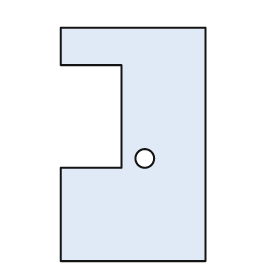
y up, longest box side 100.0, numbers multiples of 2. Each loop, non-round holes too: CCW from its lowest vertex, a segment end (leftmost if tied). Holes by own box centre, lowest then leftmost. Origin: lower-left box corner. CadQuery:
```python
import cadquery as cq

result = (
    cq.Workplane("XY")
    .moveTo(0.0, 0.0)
    .lineTo(62.0, 0.0)
    .lineTo(62.0, 100.0)
    .lineTo(0.0, 100.0)
    .lineTo(0.0, 84.0)
    .lineTo(26.0, 84.0)
    .lineTo(26.0, 40.0)
    .lineTo(0.0, 40.0)
    .close()
    .moveTo(36.0, 44.0)
    .circle(4.0)
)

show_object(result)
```